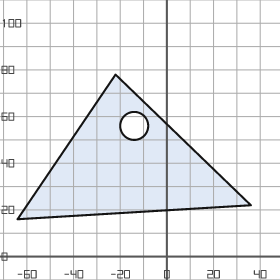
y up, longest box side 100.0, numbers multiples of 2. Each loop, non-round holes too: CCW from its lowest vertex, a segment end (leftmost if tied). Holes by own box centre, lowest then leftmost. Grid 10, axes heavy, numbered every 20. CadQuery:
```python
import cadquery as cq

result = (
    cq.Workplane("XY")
    .moveTo(-64.0, 16.0)
    .lineTo(36.0, 22.0)
    .lineTo(-22.0, 78.0)
    .close()
    .moveTo(-14.0, 56.0)
    .circle(6.0)
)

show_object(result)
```